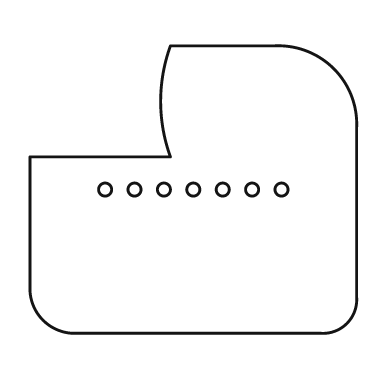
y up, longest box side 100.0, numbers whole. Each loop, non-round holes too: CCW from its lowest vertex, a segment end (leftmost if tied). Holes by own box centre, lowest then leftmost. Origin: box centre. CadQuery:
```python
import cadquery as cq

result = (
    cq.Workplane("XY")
    .moveTo(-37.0, -44.0)
    .lineTo(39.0, -44.0)
    .threePointArc((47.0, -41.0), (50.0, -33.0))
    .lineTo(50.0, 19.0)
    .threePointArc((43.0, 37.0), (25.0, 44.0))
    .lineTo(-7.0, 44.0)
    .threePointArc((-10.0, 27.0), (-7.0, 10.0))
    .lineTo(-50.0, 10.0)
    .lineTo(-50.0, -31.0)
    .threePointArc((-46.0, -40.0), (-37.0, -44.0))
    .close()
    .moveTo(-27.0, 0.0)
    .circle(2.0)
    .moveTo(-18.0, 0.0)
    .circle(2.0)
    .moveTo(-9.0, 0.0)
    .circle(2.0)
    .moveTo(0.0, 0.0)
    .circle(2.0)
    .moveTo(9.0, 0.0)
    .circle(2.0)
    .moveTo(18.0, 0.0)
    .circle(2.0)
    .moveTo(27.0, 0.0)
    .circle(2.0)
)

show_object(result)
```